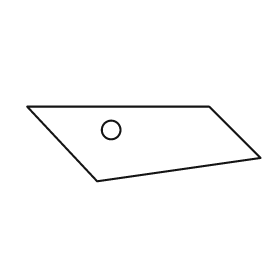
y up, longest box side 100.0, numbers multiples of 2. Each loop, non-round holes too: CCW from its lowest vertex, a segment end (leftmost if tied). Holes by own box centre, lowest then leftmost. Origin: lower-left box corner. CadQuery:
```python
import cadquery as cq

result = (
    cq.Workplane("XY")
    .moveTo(30.0, 0.0)
    .lineTo(100.0, 10.0)
    .lineTo(78.0, 32.0)
    .lineTo(0.0, 32.0)
    .close()
    .moveTo(36.0, 22.0)
    .circle(4.0)
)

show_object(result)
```